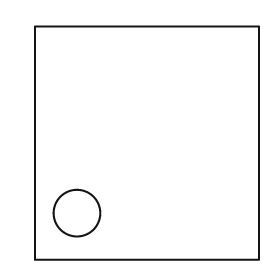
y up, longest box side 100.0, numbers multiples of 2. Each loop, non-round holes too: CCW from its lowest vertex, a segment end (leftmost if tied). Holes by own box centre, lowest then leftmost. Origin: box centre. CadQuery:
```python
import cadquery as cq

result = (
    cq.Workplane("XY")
    .moveTo(-48.0, -50.0)
    .lineTo(48.0, -50.0)
    .lineTo(48.0, 50.0)
    .lineTo(-48.0, 50.0)
    .close()
    .moveTo(-30.0, -30.0)
    .circle(10.0)
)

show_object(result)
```